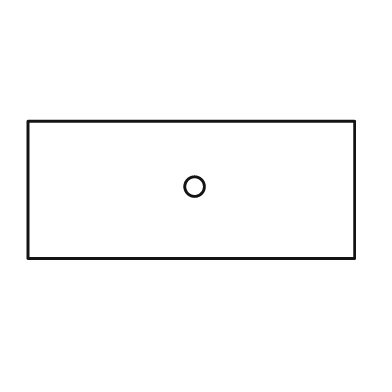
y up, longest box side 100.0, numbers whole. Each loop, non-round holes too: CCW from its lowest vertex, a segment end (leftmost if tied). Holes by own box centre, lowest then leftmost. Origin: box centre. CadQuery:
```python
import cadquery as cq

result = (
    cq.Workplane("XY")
    .moveTo(-50.0, -21.0)
    .lineTo(50.0, -21.0)
    .lineTo(50.0, 21.0)
    .lineTo(-50.0, 21.0)
    .close()
    .moveTo(1.0, 1.0)
    .circle(3.0)
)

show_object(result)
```